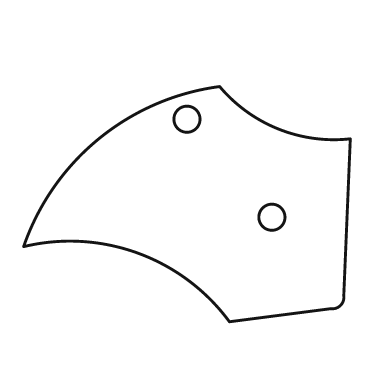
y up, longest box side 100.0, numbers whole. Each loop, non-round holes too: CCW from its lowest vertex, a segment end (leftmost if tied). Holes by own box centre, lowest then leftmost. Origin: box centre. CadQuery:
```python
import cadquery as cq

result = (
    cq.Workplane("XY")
    .moveTo(13.0, -36.0)
    .lineTo(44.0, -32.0)
    .threePointArc((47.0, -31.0), (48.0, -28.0))
    .lineTo(50.0, 20.0)
    .threePointArc((28.0, 23.0), (10.0, 36.0))
    .threePointArc((-27.0, 20.0), (-50.0, -13.0))
    .threePointArc((-15.0, -15.0), (13.0, -36.0))
    .close()
    .moveTo(26.0, -4.0)
    .circle(4.0)
    .moveTo(0.0, 26.0)
    .circle(4.0)
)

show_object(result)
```